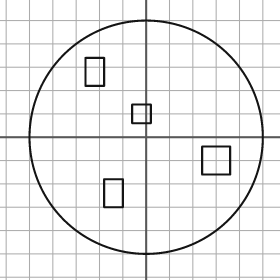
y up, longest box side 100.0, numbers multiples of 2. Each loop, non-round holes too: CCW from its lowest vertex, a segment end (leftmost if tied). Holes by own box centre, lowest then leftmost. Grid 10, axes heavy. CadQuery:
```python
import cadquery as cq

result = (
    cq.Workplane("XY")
    .moveTo(0.0, 0.0)
    .circle(50.0)
    .moveTo(-18.0, -30.0)
    .lineTo(-10.0, -30.0)
    .lineTo(-10.0, -18.0)
    .lineTo(-18.0, -18.0)
    .close()
    .moveTo(24.0, -16.0)
    .lineTo(36.0, -16.0)
    .lineTo(36.0, -4.0)
    .lineTo(24.0, -4.0)
    .close()
    .moveTo(-6.0, 6.0)
    .lineTo(2.0, 6.0)
    .lineTo(2.0, 14.0)
    .lineTo(-6.0, 14.0)
    .close()
    .moveTo(-26.0, 22.0)
    .lineTo(-18.0, 22.0)
    .lineTo(-18.0, 34.0)
    .lineTo(-26.0, 34.0)
    .close()
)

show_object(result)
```